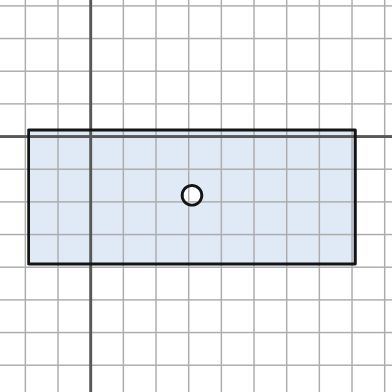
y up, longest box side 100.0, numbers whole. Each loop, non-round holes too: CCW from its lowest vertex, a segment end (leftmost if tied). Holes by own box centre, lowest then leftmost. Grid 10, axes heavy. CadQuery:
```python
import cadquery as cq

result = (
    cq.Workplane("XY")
    .moveTo(-19.0, -39.0)
    .lineTo(81.0, -39.0)
    .lineTo(81.0, 2.0)
    .lineTo(-19.0, 2.0)
    .close()
    .moveTo(31.0, -18.0)
    .circle(3.0)
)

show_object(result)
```